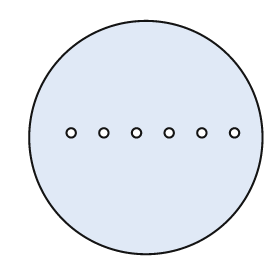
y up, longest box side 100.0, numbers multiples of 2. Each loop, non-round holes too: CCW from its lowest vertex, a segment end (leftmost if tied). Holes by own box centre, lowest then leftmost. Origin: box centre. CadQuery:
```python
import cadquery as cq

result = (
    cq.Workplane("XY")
    .moveTo(0.0, 0.0)
    .circle(50.0)
    .moveTo(-32.0, 2.0)
    .circle(2.0)
    .moveTo(-18.0, 2.0)
    .circle(2.0)
    .moveTo(-4.0, 2.0)
    .circle(2.0)
    .moveTo(10.0, 2.0)
    .circle(2.0)
    .moveTo(24.0, 2.0)
    .circle(2.0)
    .moveTo(38.0, 2.0)
    .circle(2.0)
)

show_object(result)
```